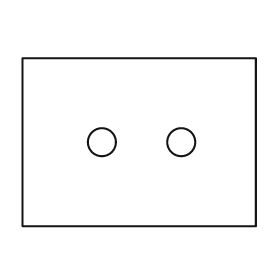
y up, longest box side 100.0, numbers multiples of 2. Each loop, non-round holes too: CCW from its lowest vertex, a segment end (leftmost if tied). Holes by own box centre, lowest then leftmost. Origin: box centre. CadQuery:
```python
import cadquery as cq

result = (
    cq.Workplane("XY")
    .moveTo(-50.0, -36.0)
    .lineTo(50.0, -36.0)
    .lineTo(50.0, 36.0)
    .lineTo(-50.0, 36.0)
    .close()
    .moveTo(-16.0, 0.0)
    .circle(6.0)
    .moveTo(18.0, 0.0)
    .circle(6.0)
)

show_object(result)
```